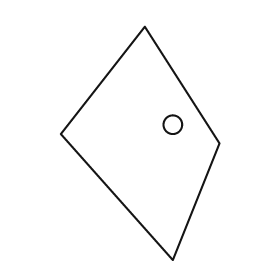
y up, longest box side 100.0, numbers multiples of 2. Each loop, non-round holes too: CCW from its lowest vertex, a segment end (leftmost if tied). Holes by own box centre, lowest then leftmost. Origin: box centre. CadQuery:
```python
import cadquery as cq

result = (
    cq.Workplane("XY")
    .moveTo(14.0, -50.0)
    .lineTo(34.0, 0.0)
    .lineTo(2.0, 50.0)
    .lineTo(-34.0, 4.0)
    .close()
    .moveTo(14.0, 8.0)
    .circle(4.0)
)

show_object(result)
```